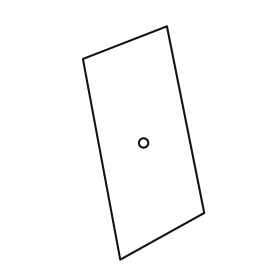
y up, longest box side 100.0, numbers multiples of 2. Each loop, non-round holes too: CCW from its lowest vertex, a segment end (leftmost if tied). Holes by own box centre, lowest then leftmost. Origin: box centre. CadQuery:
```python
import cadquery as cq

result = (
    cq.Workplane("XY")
    .moveTo(-10.0, -50.0)
    .lineTo(26.0, -30.0)
    .lineTo(10.0, 50.0)
    .lineTo(-26.0, 36.0)
    .close()
    .moveTo(0.0, 0.0)
    .circle(2.0)
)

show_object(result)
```